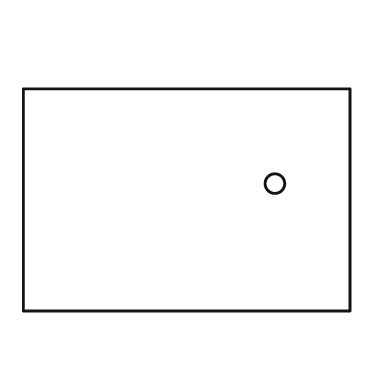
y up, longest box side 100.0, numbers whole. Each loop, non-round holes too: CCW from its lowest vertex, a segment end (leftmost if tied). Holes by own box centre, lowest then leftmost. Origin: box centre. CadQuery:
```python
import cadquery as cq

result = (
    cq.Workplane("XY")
    .moveTo(-50.0, -34.0)
    .lineTo(50.0, -34.0)
    .lineTo(50.0, 34.0)
    .lineTo(-50.0, 34.0)
    .close()
    .moveTo(27.0, 5.0)
    .circle(3.0)
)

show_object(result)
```